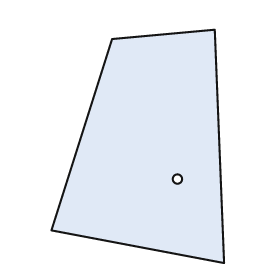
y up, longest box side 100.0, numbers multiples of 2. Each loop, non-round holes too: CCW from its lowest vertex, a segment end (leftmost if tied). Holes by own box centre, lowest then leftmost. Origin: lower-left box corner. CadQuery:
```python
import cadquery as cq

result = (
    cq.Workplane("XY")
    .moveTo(74.0, 0.0)
    .lineTo(70.0, 100.0)
    .lineTo(26.0, 96.0)
    .lineTo(0.0, 14.0)
    .close()
    .moveTo(54.0, 36.0)
    .circle(2.0)
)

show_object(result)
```